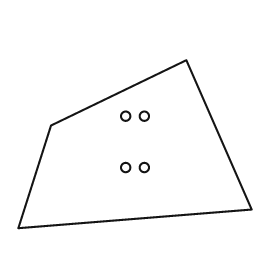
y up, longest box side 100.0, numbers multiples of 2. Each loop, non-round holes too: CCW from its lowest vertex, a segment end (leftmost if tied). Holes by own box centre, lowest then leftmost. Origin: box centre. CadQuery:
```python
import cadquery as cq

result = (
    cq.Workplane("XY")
    .moveTo(-50.0, -36.0)
    .lineTo(50.0, -28.0)
    .lineTo(22.0, 36.0)
    .lineTo(-36.0, 8.0)
    .close()
    .moveTo(-4.0, -10.0)
    .circle(2.0)
    .moveTo(4.0, -10.0)
    .circle(2.0)
    .moveTo(-4.0, 12.0)
    .circle(2.0)
    .moveTo(4.0, 12.0)
    .circle(2.0)
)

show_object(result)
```